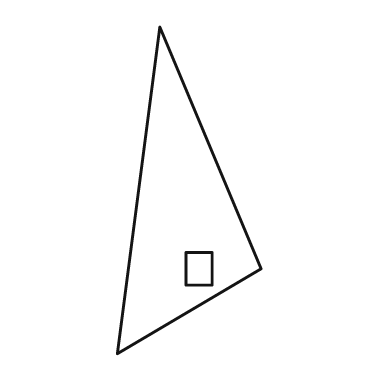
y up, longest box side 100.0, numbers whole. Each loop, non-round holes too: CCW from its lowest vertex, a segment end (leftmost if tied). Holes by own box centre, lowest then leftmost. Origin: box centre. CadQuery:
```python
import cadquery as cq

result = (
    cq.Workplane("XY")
    .moveTo(-22.0, -50.0)
    .lineTo(22.0, -24.0)
    .lineTo(-9.0, 50.0)
    .close()
    .moveTo(-1.0, -29.0)
    .lineTo(7.0, -29.0)
    .lineTo(7.0, -19.0)
    .lineTo(-1.0, -19.0)
    .close()
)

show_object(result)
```